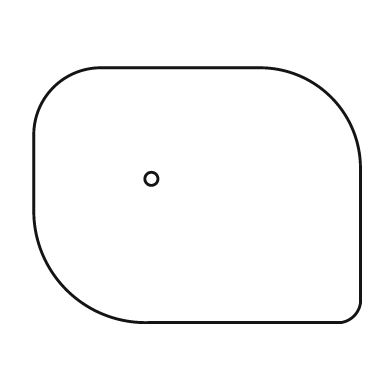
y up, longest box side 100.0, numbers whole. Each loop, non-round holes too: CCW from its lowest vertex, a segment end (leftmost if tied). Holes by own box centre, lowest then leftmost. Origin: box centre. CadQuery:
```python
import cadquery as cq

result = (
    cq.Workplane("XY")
    .moveTo(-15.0, -39.0)
    .lineTo(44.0, -39.0)
    .threePointArc((48.0, -37.0), (50.0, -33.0))
    .lineTo(50.0, 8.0)
    .threePointArc((41.0, 30.0), (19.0, 39.0))
    .lineTo(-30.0, 39.0)
    .threePointArc((-44.0, 33.0), (-50.0, 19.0))
    .lineTo(-50.0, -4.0)
    .threePointArc((-40.0, -29.0), (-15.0, -39.0))
    .close()
    .moveTo(-14.0, 5.0)
    .circle(2.0)
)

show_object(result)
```